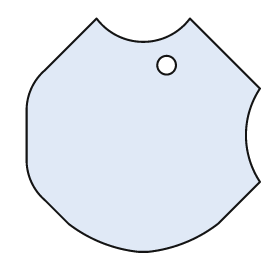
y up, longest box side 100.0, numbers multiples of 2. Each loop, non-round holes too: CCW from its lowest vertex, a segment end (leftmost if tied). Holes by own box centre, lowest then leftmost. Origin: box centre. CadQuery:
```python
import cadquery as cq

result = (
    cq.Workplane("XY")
    .moveTo(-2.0, -50.0)
    .lineTo(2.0, -50.0)
    .threePointArc((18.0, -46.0), (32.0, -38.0))
    .lineTo(50.0, -20.0)
    .threePointArc((44.0, 0.0), (50.0, 20.0))
    .lineTo(20.0, 50.0)
    .threePointArc((0.0, 40.0), (-20.0, 50.0))
    .lineTo(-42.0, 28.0)
    .threePointArc((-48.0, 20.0), (-50.0, 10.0))
    .lineTo(-50.0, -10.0)
    .threePointArc((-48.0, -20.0), (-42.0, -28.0))
    .lineTo(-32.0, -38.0)
    .threePointArc((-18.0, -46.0), (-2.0, -50.0))
    .close()
    .moveTo(10.0, 30.0)
    .circle(4.0)
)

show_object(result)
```